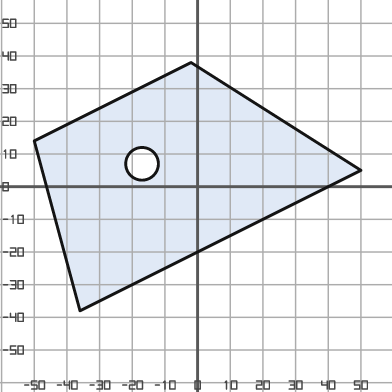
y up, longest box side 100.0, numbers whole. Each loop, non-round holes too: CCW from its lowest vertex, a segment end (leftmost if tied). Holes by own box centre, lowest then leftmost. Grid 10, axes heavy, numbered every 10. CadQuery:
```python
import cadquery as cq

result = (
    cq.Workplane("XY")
    .moveTo(-36.0, -38.0)
    .lineTo(50.0, 5.0)
    .lineTo(-2.0, 38.0)
    .lineTo(-50.0, 14.0)
    .close()
    .moveTo(-17.0, 7.0)
    .circle(5.0)
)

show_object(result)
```